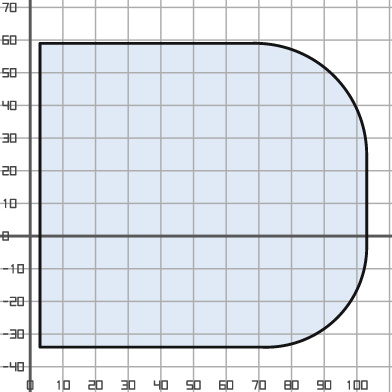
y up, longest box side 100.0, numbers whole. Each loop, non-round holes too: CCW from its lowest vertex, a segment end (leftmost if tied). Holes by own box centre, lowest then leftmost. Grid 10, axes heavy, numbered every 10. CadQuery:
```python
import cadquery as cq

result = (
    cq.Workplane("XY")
    .moveTo(3.0, -34.0)
    .lineTo(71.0, -34.0)
    .threePointArc((94.0, -25.0), (103.0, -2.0))
    .lineTo(103.0, 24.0)
    .threePointArc((93.0, 49.0), (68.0, 59.0))
    .lineTo(3.0, 59.0)
    .close()
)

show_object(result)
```